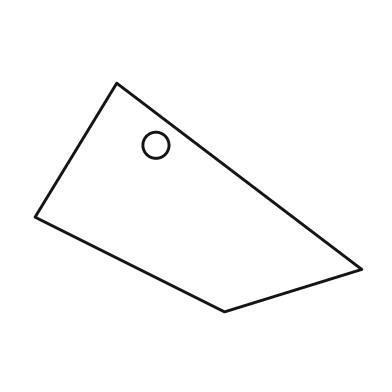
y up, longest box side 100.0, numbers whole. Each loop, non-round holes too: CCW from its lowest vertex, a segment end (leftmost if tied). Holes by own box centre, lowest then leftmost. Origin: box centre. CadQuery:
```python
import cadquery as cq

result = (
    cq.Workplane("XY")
    .moveTo(8.0, -35.0)
    .lineTo(50.0, -22.0)
    .lineTo(-25.0, 35.0)
    .lineTo(-50.0, -6.0)
    .close()
    .moveTo(-13.0, 16.0)
    .circle(4.0)
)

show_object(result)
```